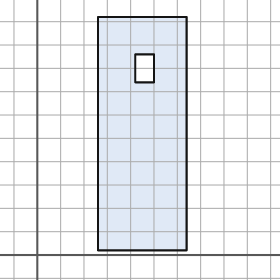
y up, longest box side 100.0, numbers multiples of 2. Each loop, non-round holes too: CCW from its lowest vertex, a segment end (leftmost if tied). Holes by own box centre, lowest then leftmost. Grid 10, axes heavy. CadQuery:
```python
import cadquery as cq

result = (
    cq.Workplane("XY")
    .moveTo(26.0, 2.0)
    .lineTo(64.0, 2.0)
    .lineTo(64.0, 102.0)
    .lineTo(26.0, 102.0)
    .close()
    .moveTo(42.0, 74.0)
    .lineTo(50.0, 74.0)
    .lineTo(50.0, 86.0)
    .lineTo(42.0, 86.0)
    .close()
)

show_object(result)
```